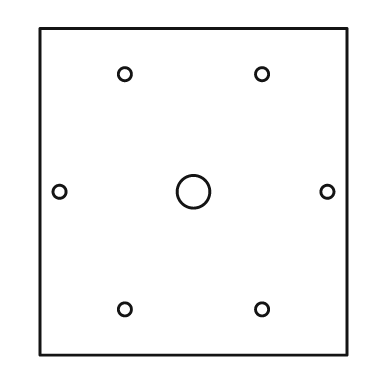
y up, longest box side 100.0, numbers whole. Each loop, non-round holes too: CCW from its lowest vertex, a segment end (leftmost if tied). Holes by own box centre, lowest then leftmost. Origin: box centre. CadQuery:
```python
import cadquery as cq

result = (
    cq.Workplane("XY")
    .moveTo(-47.0, -50.0)
    .lineTo(47.0, -50.0)
    .lineTo(47.0, 50.0)
    .lineTo(-47.0, 50.0)
    .close()
    .moveTo(-21.0, -36.0)
    .circle(2.0)
    .moveTo(21.0, -36.0)
    .circle(2.0)
    .moveTo(-41.0, 0.0)
    .circle(2.0)
    .moveTo(0.0, 0.0)
    .circle(5.0)
    .moveTo(41.0, 0.0)
    .circle(2.0)
    .moveTo(-21.0, 36.0)
    .circle(2.0)
    .moveTo(21.0, 36.0)
    .circle(2.0)
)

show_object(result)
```